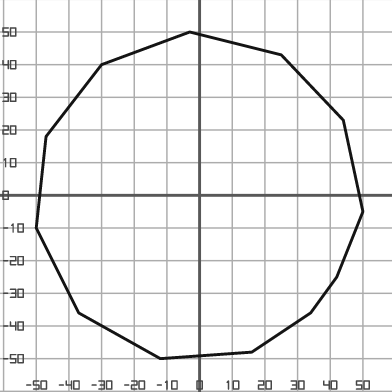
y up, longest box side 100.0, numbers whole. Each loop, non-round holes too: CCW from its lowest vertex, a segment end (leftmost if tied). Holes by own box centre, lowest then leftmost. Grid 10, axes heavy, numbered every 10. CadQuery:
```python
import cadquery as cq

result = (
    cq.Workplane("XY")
    .moveTo(-12.0, -50.0)
    .lineTo(16.0, -48.0)
    .lineTo(34.0, -36.0)
    .lineTo(42.0, -25.0)
    .lineTo(50.0, -5.0)
    .lineTo(44.0, 23.0)
    .lineTo(25.0, 43.0)
    .lineTo(-3.0, 50.0)
    .lineTo(-30.0, 40.0)
    .lineTo(-47.0, 18.0)
    .lineTo(-50.0, -10.0)
    .lineTo(-37.0, -36.0)
    .close()
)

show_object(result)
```